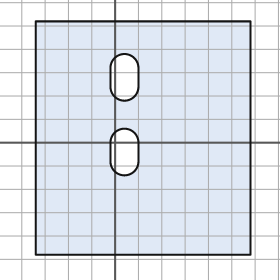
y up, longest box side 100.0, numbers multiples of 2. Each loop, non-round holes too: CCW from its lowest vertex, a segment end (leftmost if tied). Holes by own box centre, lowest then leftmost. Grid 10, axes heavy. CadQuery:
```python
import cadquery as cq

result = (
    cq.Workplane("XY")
    .moveTo(-34.0, -48.0)
    .lineTo(58.0, -48.0)
    .lineTo(58.0, 52.0)
    .lineTo(-34.0, 52.0)
    .close()
    .moveTo(-2.0, -8.0)
    .threePointArc((4.0, -14.0), (10.0, -8.0))
    .lineTo(10.0, 0.0)
    .threePointArc((4.0, 6.0), (-2.0, 0.0))
    .close()
    .moveTo(-2.0, 24.0)
    .threePointArc((4.0, 18.0), (10.0, 24.0))
    .lineTo(10.0, 32.0)
    .threePointArc((4.0, 38.0), (-2.0, 32.0))
    .close()
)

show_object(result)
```